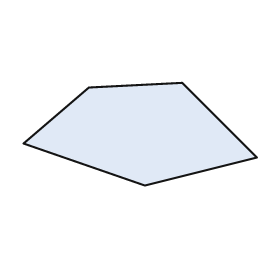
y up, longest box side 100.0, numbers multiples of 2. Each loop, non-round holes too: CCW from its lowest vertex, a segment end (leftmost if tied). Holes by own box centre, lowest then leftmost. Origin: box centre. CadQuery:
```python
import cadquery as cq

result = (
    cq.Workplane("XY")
    .moveTo(2.0, -22.0)
    .lineTo(50.0, -10.0)
    .lineTo(18.0, 22.0)
    .lineTo(-22.0, 20.0)
    .lineTo(-50.0, -4.0)
    .close()
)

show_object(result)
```